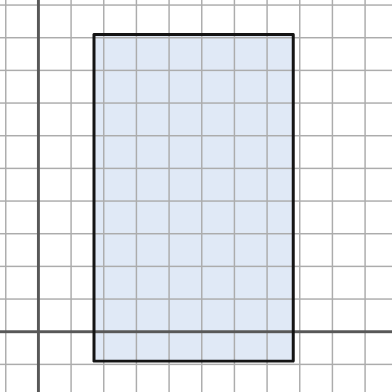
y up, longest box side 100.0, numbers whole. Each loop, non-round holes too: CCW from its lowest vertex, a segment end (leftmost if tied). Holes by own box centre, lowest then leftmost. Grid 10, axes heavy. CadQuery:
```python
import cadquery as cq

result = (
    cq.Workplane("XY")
    .moveTo(17.0, -9.0)
    .lineTo(78.0, -9.0)
    .lineTo(78.0, 91.0)
    .lineTo(17.0, 91.0)
    .close()
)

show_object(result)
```